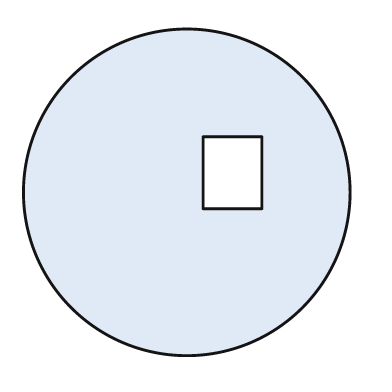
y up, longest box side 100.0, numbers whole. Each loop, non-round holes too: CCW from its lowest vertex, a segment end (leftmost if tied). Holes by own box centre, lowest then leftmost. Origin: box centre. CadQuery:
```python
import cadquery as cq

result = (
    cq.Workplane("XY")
    .moveTo(0.0, 0.0)
    .circle(50.0)
    .moveTo(5.0, -5.0)
    .lineTo(23.0, -5.0)
    .lineTo(23.0, 17.0)
    .lineTo(5.0, 17.0)
    .close()
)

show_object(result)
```